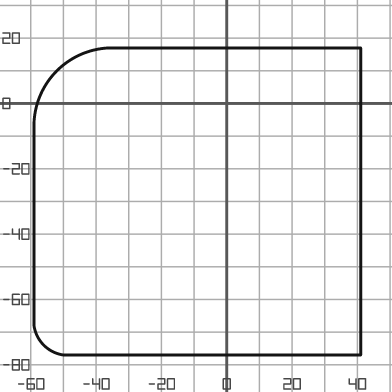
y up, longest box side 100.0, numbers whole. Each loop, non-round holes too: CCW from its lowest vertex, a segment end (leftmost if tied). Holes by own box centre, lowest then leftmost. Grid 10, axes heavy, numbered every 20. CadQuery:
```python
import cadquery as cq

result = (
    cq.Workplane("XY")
    .moveTo(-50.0, -77.0)
    .lineTo(41.0, -77.0)
    .lineTo(41.0, 17.0)
    .lineTo(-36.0, 17.0)
    .threePointArc((-52.0, 10.0), (-59.0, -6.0))
    .lineTo(-59.0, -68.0)
    .threePointArc((-56.0, -74.0), (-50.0, -77.0))
    .close()
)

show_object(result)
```